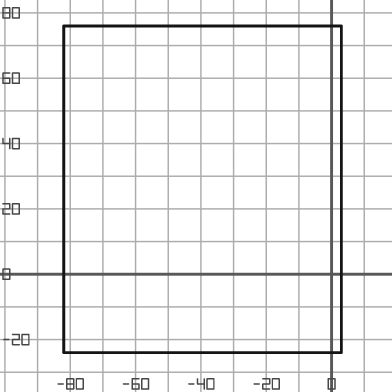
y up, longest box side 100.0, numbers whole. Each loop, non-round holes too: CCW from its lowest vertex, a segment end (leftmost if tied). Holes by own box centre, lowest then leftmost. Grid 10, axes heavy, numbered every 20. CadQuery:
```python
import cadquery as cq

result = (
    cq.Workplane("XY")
    .moveTo(-82.0, -24.0)
    .lineTo(3.0, -24.0)
    .lineTo(3.0, 76.0)
    .lineTo(-82.0, 76.0)
    .close()
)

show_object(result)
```